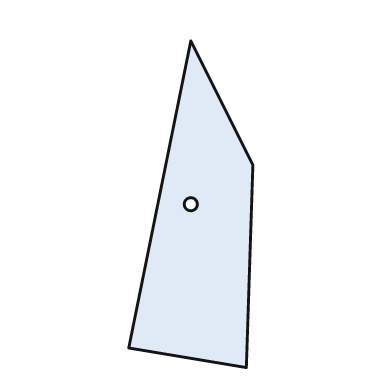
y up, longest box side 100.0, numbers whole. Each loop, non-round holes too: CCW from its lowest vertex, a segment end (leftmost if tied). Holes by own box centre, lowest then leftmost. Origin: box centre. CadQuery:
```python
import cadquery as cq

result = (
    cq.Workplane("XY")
    .moveTo(17.0, -50.0)
    .lineTo(19.0, 12.0)
    .lineTo(0.0, 50.0)
    .lineTo(-19.0, -44.0)
    .close()
    .moveTo(0.0, 0.0)
    .circle(2.0)
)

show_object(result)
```